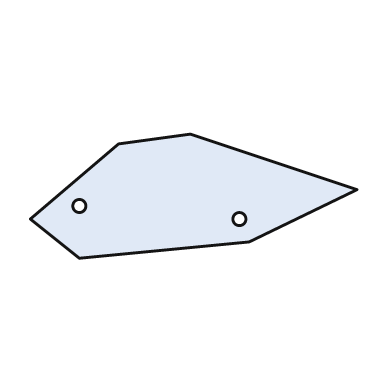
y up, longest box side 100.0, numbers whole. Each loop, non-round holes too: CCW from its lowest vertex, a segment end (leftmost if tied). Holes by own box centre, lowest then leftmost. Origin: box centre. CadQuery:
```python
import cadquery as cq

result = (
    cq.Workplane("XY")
    .moveTo(-35.0, -19.0)
    .lineTo(17.0, -14.0)
    .lineTo(50.0, 2.0)
    .lineTo(-1.0, 19.0)
    .lineTo(-23.0, 16.0)
    .lineTo(-50.0, -7.0)
    .close()
    .moveTo(14.0, -7.0)
    .circle(2.0)
    .moveTo(-35.0, -3.0)
    .circle(2.0)
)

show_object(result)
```